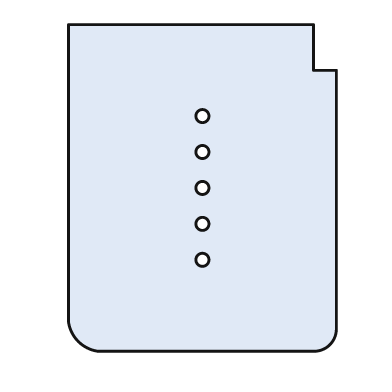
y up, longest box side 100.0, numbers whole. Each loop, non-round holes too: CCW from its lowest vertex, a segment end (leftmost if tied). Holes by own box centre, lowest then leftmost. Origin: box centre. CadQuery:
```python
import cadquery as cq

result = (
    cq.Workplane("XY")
    .moveTo(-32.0, -50.0)
    .lineTo(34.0, -50.0)
    .threePointArc((39.0, -48.0), (41.0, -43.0))
    .lineTo(41.0, 36.0)
    .lineTo(34.0, 36.0)
    .lineTo(34.0, 50.0)
    .lineTo(-41.0, 50.0)
    .lineTo(-41.0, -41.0)
    .threePointArc((-38.0, -47.0), (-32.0, -50.0))
    .close()
    .moveTo(0.0, -22.0)
    .circle(2.0)
    .moveTo(0.0, -11.0)
    .circle(2.0)
    .moveTo(0.0, 0.0)
    .circle(2.0)
    .moveTo(0.0, 11.0)
    .circle(2.0)
    .moveTo(0.0, 22.0)
    .circle(2.0)
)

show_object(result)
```